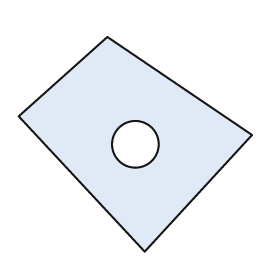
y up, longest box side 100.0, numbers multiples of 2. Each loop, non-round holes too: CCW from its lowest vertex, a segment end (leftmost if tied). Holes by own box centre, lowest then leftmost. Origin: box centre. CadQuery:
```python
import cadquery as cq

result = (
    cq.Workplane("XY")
    .moveTo(4.0, -46.0)
    .lineTo(50.0, 4.0)
    .lineTo(-12.0, 46.0)
    .lineTo(-50.0, 12.0)
    .close()
    .moveTo(0.0, 0.0)
    .circle(10.0)
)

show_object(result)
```